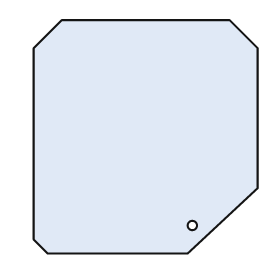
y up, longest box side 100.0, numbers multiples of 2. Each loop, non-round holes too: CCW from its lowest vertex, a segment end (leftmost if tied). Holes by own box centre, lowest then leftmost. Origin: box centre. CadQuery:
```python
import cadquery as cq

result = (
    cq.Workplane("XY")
    .moveTo(-42.0, -50.0)
    .lineTo(18.0, -50.0)
    .lineTo(48.0, -22.0)
    .lineTo(48.0, 38.0)
    .lineTo(36.0, 50.0)
    .lineTo(-36.0, 50.0)
    .lineTo(-48.0, 38.0)
    .lineTo(-48.0, -44.0)
    .close()
    .moveTo(20.0, -38.0)
    .circle(2.0)
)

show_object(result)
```